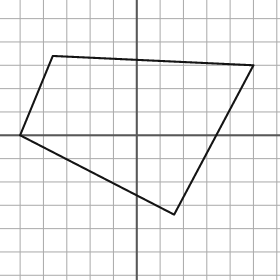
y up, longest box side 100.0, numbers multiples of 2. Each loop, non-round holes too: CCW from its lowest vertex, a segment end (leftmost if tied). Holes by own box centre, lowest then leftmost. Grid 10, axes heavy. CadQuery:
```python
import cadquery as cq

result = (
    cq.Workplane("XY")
    .moveTo(16.0, -34.0)
    .lineTo(50.0, 30.0)
    .lineTo(-36.0, 34.0)
    .lineTo(-50.0, 0.0)
    .close()
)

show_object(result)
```